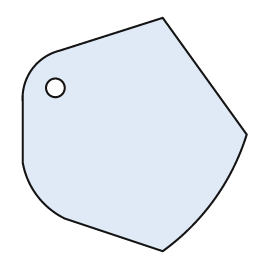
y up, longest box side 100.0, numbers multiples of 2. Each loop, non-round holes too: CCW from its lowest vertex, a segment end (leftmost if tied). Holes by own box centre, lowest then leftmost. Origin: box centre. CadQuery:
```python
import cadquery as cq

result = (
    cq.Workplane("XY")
    .moveTo(12.0, -50.0)
    .threePointArc((34.0, -28.0), (48.0, 0.0))
    .lineTo(12.0, 50.0)
    .lineTo(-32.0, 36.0)
    .threePointArc((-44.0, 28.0), (-48.0, 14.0))
    .lineTo(-48.0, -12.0)
    .threePointArc((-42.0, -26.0), (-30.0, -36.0))
    .close()
    .moveTo(-34.0, 20.0)
    .circle(4.0)
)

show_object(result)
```